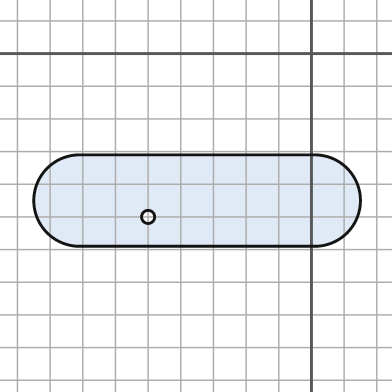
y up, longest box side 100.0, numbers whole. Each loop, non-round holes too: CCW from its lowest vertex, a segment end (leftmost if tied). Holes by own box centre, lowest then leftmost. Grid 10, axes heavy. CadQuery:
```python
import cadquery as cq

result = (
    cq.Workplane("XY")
    .moveTo(-71.0, -59.0)
    .lineTo(1.0, -59.0)
    .threePointArc((15.0, -45.0), (1.0, -31.0))
    .lineTo(-71.0, -31.0)
    .threePointArc((-85.0, -45.0), (-71.0, -59.0))
    .close()
    .moveTo(-50.0, -50.0)
    .circle(2.0)
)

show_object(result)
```